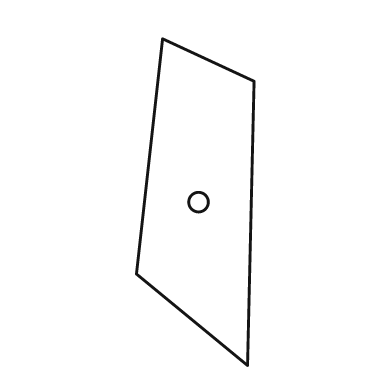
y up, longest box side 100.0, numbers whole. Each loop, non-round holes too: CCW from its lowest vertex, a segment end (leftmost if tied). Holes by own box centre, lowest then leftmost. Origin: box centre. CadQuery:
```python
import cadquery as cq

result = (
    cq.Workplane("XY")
    .moveTo(16.0, -50.0)
    .lineTo(18.0, 37.0)
    .lineTo(-10.0, 50.0)
    .lineTo(-18.0, -22.0)
    .close()
    .moveTo(1.0, 0.0)
    .circle(3.0)
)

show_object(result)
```